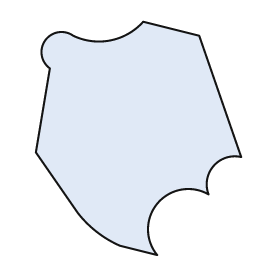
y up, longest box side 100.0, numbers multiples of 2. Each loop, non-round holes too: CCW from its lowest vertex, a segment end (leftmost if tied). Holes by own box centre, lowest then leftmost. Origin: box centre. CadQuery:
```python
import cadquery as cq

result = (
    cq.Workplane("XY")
    .moveTo(8.0, -50.0)
    .threePointArc((8.0, -28.0), (30.0, -24.0))
    .threePointArc((32.0, -12.0), (44.0, -8.0))
    .lineTo(26.0, 44.0)
    .lineTo(2.0, 50.0)
    .threePointArc((-12.0, 42.0), (-28.0, 44.0))
    .threePointArc((-40.0, 42.0), (-38.0, 30.0))
    .lineTo(-44.0, -6.0)
    .lineTo(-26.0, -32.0)
    .threePointArc((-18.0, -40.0), (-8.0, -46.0))
    .close()
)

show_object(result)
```